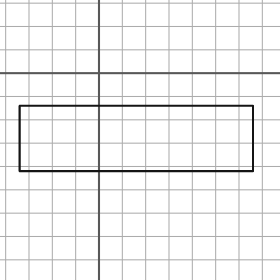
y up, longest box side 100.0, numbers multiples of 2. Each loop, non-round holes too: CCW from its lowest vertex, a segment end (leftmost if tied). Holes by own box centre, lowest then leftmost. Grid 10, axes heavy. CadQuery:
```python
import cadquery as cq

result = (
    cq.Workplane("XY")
    .moveTo(-34.0, -42.0)
    .lineTo(66.0, -42.0)
    .lineTo(66.0, -14.0)
    .lineTo(-34.0, -14.0)
    .close()
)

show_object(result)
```